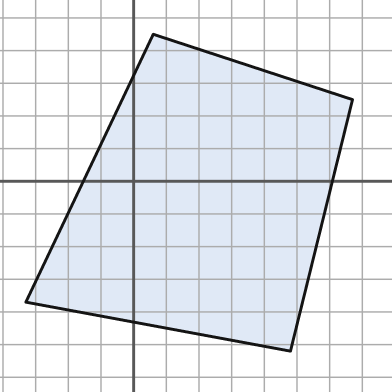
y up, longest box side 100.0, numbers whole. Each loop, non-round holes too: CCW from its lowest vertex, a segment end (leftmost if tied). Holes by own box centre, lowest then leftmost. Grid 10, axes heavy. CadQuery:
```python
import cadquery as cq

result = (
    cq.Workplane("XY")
    .moveTo(48.0, -52.0)
    .lineTo(67.0, 25.0)
    .lineTo(6.0, 45.0)
    .lineTo(-33.0, -37.0)
    .close()
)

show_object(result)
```